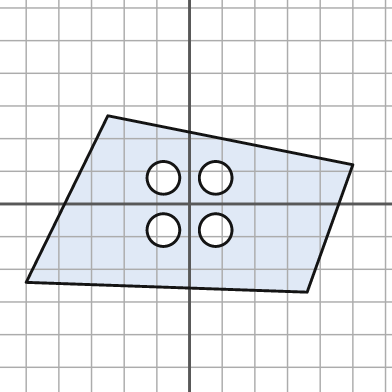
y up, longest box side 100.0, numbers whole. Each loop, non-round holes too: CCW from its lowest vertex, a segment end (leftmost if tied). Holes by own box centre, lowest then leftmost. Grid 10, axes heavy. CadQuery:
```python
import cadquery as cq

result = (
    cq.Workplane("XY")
    .moveTo(36.0, -27.0)
    .lineTo(50.0, 12.0)
    .lineTo(-25.0, 27.0)
    .lineTo(-50.0, -24.0)
    .close()
    .moveTo(-8.0, -8.0)
    .circle(5.0)
    .moveTo(8.0, -8.0)
    .circle(5.0)
    .moveTo(-8.0, 8.0)
    .circle(5.0)
    .moveTo(8.0, 8.0)
    .circle(5.0)
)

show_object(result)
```